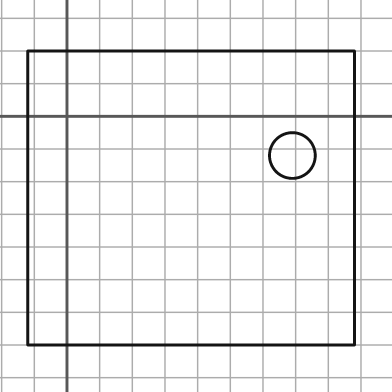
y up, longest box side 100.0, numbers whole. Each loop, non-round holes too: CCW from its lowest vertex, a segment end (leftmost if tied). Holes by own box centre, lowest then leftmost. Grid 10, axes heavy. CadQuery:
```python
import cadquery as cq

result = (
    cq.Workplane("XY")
    .moveTo(-12.0, -70.0)
    .lineTo(88.0, -70.0)
    .lineTo(88.0, 20.0)
    .lineTo(-12.0, 20.0)
    .close()
    .moveTo(69.0, -12.0)
    .circle(7.0)
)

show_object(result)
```